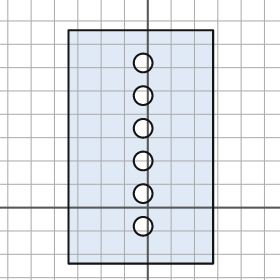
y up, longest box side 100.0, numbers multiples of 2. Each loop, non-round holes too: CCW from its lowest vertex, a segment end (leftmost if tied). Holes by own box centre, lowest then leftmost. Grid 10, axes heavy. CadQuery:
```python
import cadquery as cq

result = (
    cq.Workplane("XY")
    .moveTo(-34.0, -24.0)
    .lineTo(28.0, -24.0)
    .lineTo(28.0, 76.0)
    .lineTo(-34.0, 76.0)
    .close()
    .moveTo(-2.0, -8.0)
    .circle(4.0)
    .moveTo(-2.0, 6.0)
    .circle(4.0)
    .moveTo(-2.0, 20.0)
    .circle(4.0)
    .moveTo(-2.0, 34.0)
    .circle(4.0)
    .moveTo(-2.0, 48.0)
    .circle(4.0)
    .moveTo(-2.0, 62.0)
    .circle(4.0)
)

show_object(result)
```